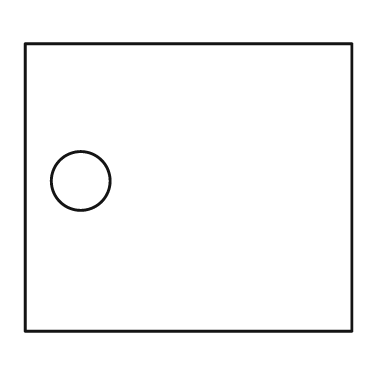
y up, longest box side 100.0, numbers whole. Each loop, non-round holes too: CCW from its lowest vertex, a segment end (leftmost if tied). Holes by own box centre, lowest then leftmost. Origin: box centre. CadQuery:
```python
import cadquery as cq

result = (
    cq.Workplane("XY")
    .moveTo(-50.0, -44.0)
    .lineTo(50.0, -44.0)
    .lineTo(50.0, 44.0)
    .lineTo(-50.0, 44.0)
    .close()
    .moveTo(-33.0, 2.0)
    .circle(9.0)
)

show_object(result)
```